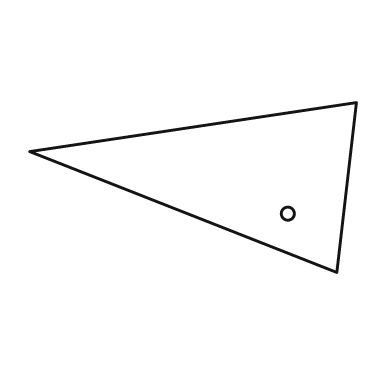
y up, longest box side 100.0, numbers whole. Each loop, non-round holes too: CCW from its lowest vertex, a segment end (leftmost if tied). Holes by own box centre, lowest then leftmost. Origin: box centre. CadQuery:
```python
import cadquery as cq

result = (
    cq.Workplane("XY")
    .moveTo(44.0, -26.0)
    .lineTo(50.0, 26.0)
    .lineTo(-50.0, 11.0)
    .close()
    .moveTo(29.0, -8.0)
    .circle(2.0)
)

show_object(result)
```